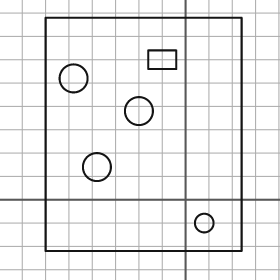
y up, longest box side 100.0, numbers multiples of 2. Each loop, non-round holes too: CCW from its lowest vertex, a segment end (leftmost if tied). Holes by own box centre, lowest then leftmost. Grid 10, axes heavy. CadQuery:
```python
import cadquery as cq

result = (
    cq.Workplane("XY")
    .moveTo(-60.0, -22.0)
    .lineTo(24.0, -22.0)
    .lineTo(24.0, 78.0)
    .lineTo(-60.0, 78.0)
    .close()
    .moveTo(8.0, -10.0)
    .circle(4.0)
    .moveTo(-38.0, 14.0)
    .circle(6.0)
    .moveTo(-20.0, 38.0)
    .circle(6.0)
    .moveTo(-48.0, 52.0)
    .circle(6.0)
    .moveTo(-16.0, 56.0)
    .lineTo(-4.0, 56.0)
    .lineTo(-4.0, 64.0)
    .lineTo(-16.0, 64.0)
    .close()
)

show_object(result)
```